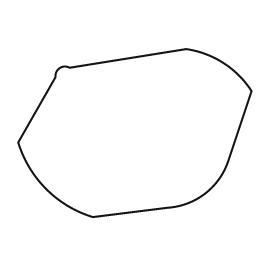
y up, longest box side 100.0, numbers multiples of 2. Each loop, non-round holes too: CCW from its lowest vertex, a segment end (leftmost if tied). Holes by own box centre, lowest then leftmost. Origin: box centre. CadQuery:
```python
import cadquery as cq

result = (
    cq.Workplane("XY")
    .moveTo(-18.0, -36.0)
    .lineTo(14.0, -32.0)
    .threePointArc((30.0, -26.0), (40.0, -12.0))
    .lineTo(50.0, 18.0)
    .threePointArc((38.0, 30.0), (22.0, 36.0))
    .lineTo(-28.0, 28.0)
    .threePointArc((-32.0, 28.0), (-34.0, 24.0))
    .lineTo(-50.0, -4.0)
    .threePointArc((-38.0, -24.0), (-18.0, -36.0))
    .close()
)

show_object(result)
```